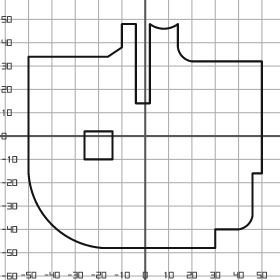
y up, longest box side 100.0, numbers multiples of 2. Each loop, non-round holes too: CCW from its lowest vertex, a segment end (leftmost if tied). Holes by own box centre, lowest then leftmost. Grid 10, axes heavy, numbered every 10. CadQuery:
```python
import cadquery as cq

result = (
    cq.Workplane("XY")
    .moveTo(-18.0, -48.0)
    .lineTo(30.0, -48.0)
    .lineTo(30.0, -40.0)
    .lineTo(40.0, -40.0)
    .threePointArc((44.0, -38.0), (46.0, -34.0))
    .lineTo(46.0, -16.0)
    .lineTo(50.0, -16.0)
    .lineTo(50.0, 32.0)
    .lineTo(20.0, 32.0)
    .threePointArc((16.0, 34.0), (14.0, 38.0))
    .lineTo(14.0, 48.0)
    .threePointArc((8.0, 46.0), (2.0, 48.0))
    .lineTo(2.0, 14.0)
    .lineTo(-4.0, 14.0)
    .lineTo(-4.0, 48.0)
    .lineTo(-10.0, 48.0)
    .lineTo(-10.0, 38.0)
    .lineTo(-16.0, 34.0)
    .lineTo(-50.0, 34.0)
    .lineTo(-50.0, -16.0)
    .threePointArc((-40.0, -38.0), (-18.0, -48.0))
    .close()
    .moveTo(-26.0, -10.0)
    .lineTo(-14.0, -10.0)
    .lineTo(-14.0, 2.0)
    .lineTo(-26.0, 2.0)
    .close()
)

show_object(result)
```